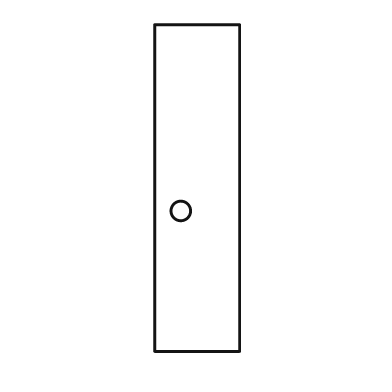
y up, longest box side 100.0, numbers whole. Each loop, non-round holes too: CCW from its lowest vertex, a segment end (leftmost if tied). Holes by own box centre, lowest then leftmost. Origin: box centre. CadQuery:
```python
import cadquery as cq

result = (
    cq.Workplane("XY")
    .moveTo(-13.0, -50.0)
    .lineTo(13.0, -50.0)
    .lineTo(13.0, 50.0)
    .lineTo(-13.0, 50.0)
    .close()
    .moveTo(-5.0, -7.0)
    .circle(3.0)
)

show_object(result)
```